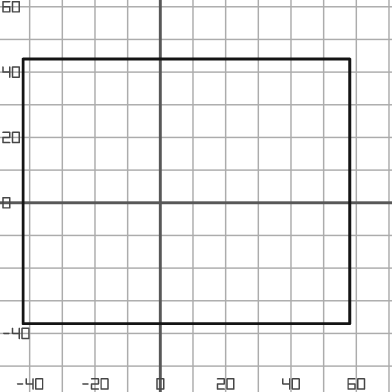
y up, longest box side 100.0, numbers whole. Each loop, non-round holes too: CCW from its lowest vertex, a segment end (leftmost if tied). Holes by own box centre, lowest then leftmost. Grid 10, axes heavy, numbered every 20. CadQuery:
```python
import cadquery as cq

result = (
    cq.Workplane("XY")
    .moveTo(-42.0, -37.0)
    .lineTo(58.0, -37.0)
    .lineTo(58.0, 44.0)
    .lineTo(-42.0, 44.0)
    .close()
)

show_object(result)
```